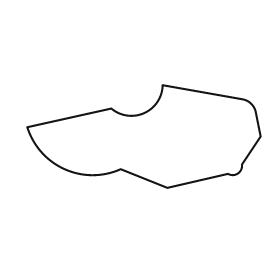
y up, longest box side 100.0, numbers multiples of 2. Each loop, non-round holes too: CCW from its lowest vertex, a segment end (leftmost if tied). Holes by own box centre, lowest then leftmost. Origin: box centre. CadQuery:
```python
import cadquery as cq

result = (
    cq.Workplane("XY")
    .moveTo(10.0, -22.0)
    .lineTo(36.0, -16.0)
    .threePointArc((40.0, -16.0), (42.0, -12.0))
    .lineTo(50.0, 0.0)
    .lineTo(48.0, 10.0)
    .threePointArc((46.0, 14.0), (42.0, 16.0))
    .lineTo(8.0, 22.0)
    .threePointArc((0.0, 10.0), (-14.0, 12.0))
    .lineTo(-50.0, 4.0)
    .threePointArc((-34.0, -14.0), (-10.0, -14.0))
    .close()
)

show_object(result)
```